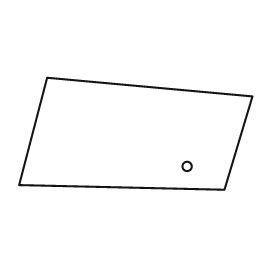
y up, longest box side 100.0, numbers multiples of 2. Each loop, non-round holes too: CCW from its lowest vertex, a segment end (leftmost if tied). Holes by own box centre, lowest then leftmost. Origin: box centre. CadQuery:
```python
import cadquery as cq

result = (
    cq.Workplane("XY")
    .moveTo(38.0, -24.0)
    .lineTo(50.0, 16.0)
    .lineTo(-38.0, 24.0)
    .lineTo(-50.0, -22.0)
    .close()
    .moveTo(22.0, -14.0)
    .circle(2.0)
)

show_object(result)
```